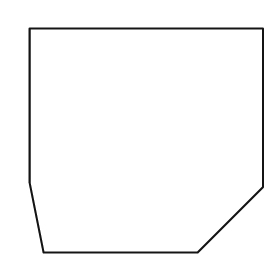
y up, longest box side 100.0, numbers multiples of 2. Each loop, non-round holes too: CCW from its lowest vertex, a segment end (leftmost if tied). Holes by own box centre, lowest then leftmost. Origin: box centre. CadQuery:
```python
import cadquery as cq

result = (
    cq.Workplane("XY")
    .moveTo(-44.0, -48.0)
    .lineTo(22.0, -48.0)
    .lineTo(50.0, -20.0)
    .lineTo(50.0, 48.0)
    .lineTo(-50.0, 48.0)
    .lineTo(-50.0, -18.0)
    .close()
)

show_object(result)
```